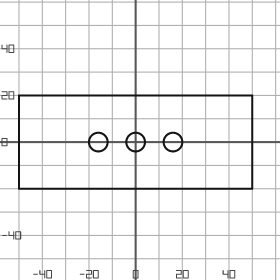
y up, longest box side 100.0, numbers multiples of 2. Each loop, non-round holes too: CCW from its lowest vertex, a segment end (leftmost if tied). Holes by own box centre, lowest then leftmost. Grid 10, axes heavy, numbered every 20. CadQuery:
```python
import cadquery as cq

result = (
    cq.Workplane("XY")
    .moveTo(-50.0, -20.0)
    .lineTo(50.0, -20.0)
    .lineTo(50.0, 20.0)
    .lineTo(-50.0, 20.0)
    .close()
    .moveTo(-16.0, 0.0)
    .circle(4.0)
    .moveTo(0.0, 0.0)
    .circle(4.0)
    .moveTo(16.0, 0.0)
    .circle(4.0)
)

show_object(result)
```